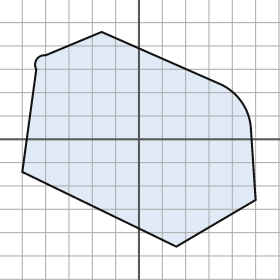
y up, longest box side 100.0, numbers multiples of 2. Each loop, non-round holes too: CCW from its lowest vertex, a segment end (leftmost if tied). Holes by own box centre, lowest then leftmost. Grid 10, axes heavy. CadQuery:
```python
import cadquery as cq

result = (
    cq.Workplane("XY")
    .moveTo(16.0, -46.0)
    .lineTo(50.0, -26.0)
    .lineTo(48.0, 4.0)
    .threePointArc((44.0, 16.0), (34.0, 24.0))
    .lineTo(-16.0, 46.0)
    .lineTo(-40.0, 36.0)
    .threePointArc((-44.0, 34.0), (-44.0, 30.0))
    .lineTo(-50.0, -14.0)
    .close()
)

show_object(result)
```